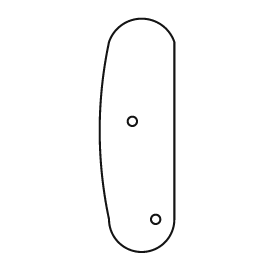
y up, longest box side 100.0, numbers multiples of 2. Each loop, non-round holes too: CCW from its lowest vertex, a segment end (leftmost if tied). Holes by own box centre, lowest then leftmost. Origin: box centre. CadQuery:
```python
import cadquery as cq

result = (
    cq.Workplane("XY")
    .moveTo(-12.0, -36.0)
    .threePointArc((2.0, -50.0), (16.0, -36.0))
    .lineTo(16.0, 40.0)
    .threePointArc((2.0, 50.0), (-12.0, 40.0))
    .threePointArc((-16.0, 2.0), (-12.0, -36.0))
    .close()
    .moveTo(8.0, -36.0)
    .circle(2.0)
    .moveTo(-2.0, 6.0)
    .circle(2.0)
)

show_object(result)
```